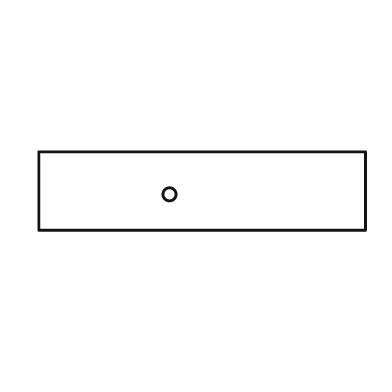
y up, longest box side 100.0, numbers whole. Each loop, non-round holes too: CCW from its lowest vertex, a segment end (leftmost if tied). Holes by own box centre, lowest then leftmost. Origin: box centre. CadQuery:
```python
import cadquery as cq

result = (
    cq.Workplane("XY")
    .moveTo(-50.0, -12.0)
    .lineTo(50.0, -12.0)
    .lineTo(50.0, 12.0)
    .lineTo(-50.0, 12.0)
    .close()
    .moveTo(-10.0, -1.0)
    .circle(2.0)
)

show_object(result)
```